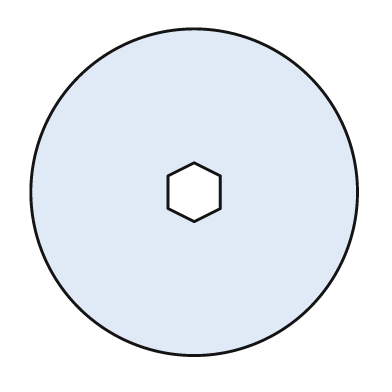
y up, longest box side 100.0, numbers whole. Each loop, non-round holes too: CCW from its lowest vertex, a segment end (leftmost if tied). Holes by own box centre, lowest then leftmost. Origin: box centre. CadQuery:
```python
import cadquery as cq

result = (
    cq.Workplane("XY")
    .moveTo(0.0, 0.0)
    .circle(50.0)
    .moveTo(0.0, -9.0)
    .lineTo(8.0, -5.0)
    .lineTo(8.0, 5.0)
    .lineTo(0.0, 9.0)
    .lineTo(-8.0, 5.0)
    .lineTo(-8.0, -5.0)
    .close()
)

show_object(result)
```